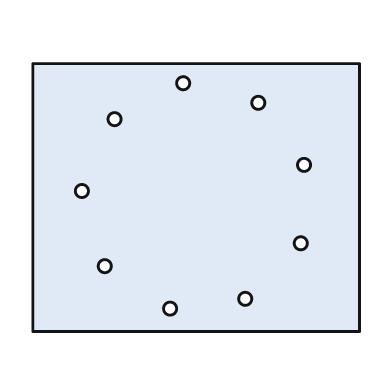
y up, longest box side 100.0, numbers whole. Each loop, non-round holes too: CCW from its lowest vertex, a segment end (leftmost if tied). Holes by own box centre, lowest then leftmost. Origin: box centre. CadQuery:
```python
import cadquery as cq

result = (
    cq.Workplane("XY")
    .moveTo(-50.0, -41.0)
    .lineTo(50.0, -41.0)
    .lineTo(50.0, 41.0)
    .lineTo(-50.0, 41.0)
    .close()
    .moveTo(-8.0, -34.0)
    .circle(2.0)
    .moveTo(15.0, -31.0)
    .circle(2.0)
    .moveTo(-28.0, -21.0)
    .circle(2.0)
    .moveTo(32.0, -14.0)
    .circle(2.0)
    .moveTo(-35.0, 2.0)
    .circle(2.0)
    .moveTo(33.0, 10.0)
    .circle(2.0)
    .moveTo(-25.0, 24.0)
    .circle(2.0)
    .moveTo(19.0, 29.0)
    .circle(2.0)
    .moveTo(-4.0, 35.0)
    .circle(2.0)
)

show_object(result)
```